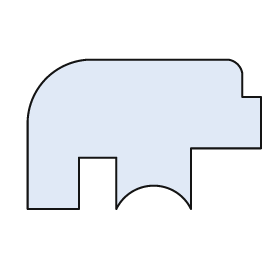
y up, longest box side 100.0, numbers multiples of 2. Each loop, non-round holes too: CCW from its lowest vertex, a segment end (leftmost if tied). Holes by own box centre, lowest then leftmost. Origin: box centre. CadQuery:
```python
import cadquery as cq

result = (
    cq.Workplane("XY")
    .moveTo(-50.0, -32.0)
    .lineTo(-28.0, -32.0)
    .lineTo(-28.0, -10.0)
    .lineTo(-12.0, -10.0)
    .lineTo(-12.0, -32.0)
    .threePointArc((4.0, -22.0), (20.0, -32.0))
    .lineTo(20.0, -6.0)
    .lineTo(50.0, -6.0)
    .lineTo(50.0, 16.0)
    .lineTo(42.0, 16.0)
    .lineTo(42.0, 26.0)
    .threePointArc((40.0, 30.0), (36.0, 32.0))
    .lineTo(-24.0, 32.0)
    .threePointArc((-42.0, 24.0), (-50.0, 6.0))
    .close()
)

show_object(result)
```